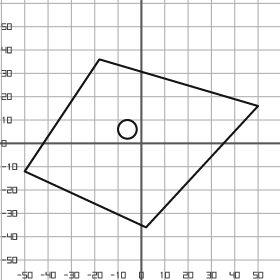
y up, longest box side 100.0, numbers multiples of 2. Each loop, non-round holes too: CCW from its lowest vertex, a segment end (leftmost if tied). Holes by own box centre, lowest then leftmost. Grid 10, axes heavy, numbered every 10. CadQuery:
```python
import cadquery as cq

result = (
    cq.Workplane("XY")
    .moveTo(2.0, -36.0)
    .lineTo(50.0, 16.0)
    .lineTo(-18.0, 36.0)
    .lineTo(-50.0, -12.0)
    .close()
    .moveTo(-6.0, 6.0)
    .circle(4.0)
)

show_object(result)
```